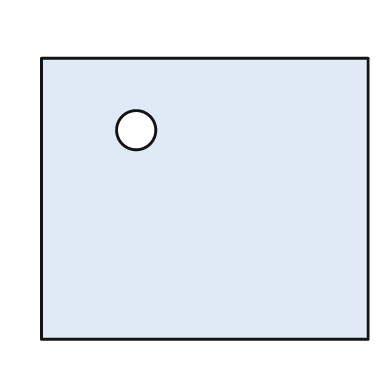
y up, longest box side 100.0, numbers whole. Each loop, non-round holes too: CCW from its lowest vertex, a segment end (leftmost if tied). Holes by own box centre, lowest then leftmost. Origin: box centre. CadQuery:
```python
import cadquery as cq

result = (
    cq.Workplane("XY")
    .moveTo(-50.0, -43.0)
    .lineTo(50.0, -43.0)
    .lineTo(50.0, 43.0)
    .lineTo(-50.0, 43.0)
    .close()
    .moveTo(-21.0, 21.0)
    .circle(6.0)
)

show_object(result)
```